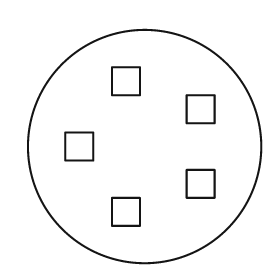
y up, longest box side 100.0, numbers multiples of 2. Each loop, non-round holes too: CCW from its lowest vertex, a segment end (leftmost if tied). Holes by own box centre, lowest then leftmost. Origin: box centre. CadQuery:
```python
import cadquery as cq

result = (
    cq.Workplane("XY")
    .moveTo(0.0, 0.0)
    .circle(50.0)
    .moveTo(-14.0, -34.0)
    .lineTo(-2.0, -34.0)
    .lineTo(-2.0, -22.0)
    .lineTo(-14.0, -22.0)
    .close()
    .moveTo(18.0, -22.0)
    .lineTo(30.0, -22.0)
    .lineTo(30.0, -10.0)
    .lineTo(18.0, -10.0)
    .close()
    .moveTo(-34.0, -6.0)
    .lineTo(-22.0, -6.0)
    .lineTo(-22.0, 6.0)
    .lineTo(-34.0, 6.0)
    .close()
    .moveTo(18.0, 10.0)
    .lineTo(30.0, 10.0)
    .lineTo(30.0, 22.0)
    .lineTo(18.0, 22.0)
    .close()
    .moveTo(-14.0, 22.0)
    .lineTo(-2.0, 22.0)
    .lineTo(-2.0, 34.0)
    .lineTo(-14.0, 34.0)
    .close()
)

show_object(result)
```